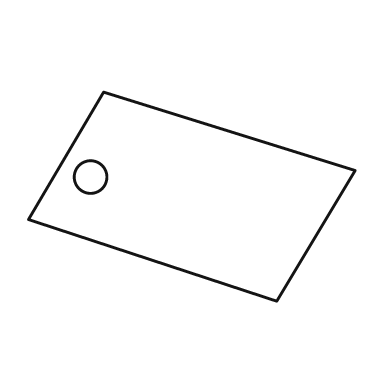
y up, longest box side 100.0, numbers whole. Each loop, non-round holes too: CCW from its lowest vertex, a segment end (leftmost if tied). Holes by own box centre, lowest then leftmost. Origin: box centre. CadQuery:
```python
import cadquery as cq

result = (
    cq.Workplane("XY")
    .moveTo(26.0, -32.0)
    .lineTo(50.0, 8.0)
    .lineTo(-27.0, 32.0)
    .lineTo(-50.0, -7.0)
    .close()
    .moveTo(-31.0, 6.0)
    .circle(5.0)
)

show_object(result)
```